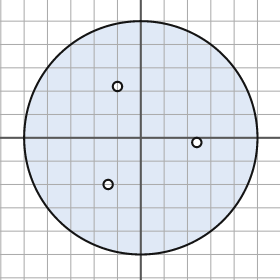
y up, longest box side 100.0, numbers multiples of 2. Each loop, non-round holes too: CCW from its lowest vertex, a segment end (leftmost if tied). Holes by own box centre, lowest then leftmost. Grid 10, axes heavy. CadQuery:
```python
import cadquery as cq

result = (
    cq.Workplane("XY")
    .moveTo(0.0, 0.0)
    .circle(50.0)
    .moveTo(-14.0, -20.0)
    .circle(2.0)
    .moveTo(24.0, -2.0)
    .circle(2.0)
    .moveTo(-10.0, 22.0)
    .circle(2.0)
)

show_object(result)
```